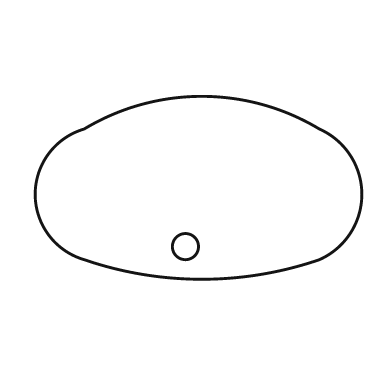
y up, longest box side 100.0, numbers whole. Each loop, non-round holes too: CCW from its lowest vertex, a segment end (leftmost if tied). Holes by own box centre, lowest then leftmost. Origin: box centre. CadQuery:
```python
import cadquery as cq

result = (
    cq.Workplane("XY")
    .moveTo(-35.0, -22.0)
    .threePointArc((1.0, -28.0), (37.0, -22.0))
    .threePointArc((50.0, -2.0), (37.0, 18.0))
    .threePointArc((1.0, 28.0), (-35.0, 18.0))
    .threePointArc((-50.0, -2.0), (-35.0, -22.0))
    .close()
    .moveTo(-4.0, -18.0)
    .circle(4.0)
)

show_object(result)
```